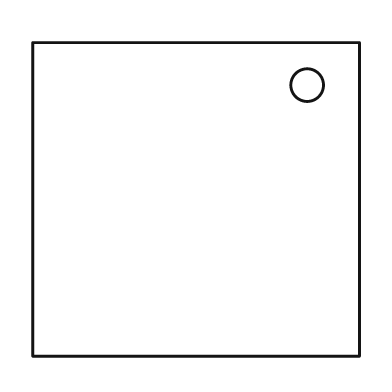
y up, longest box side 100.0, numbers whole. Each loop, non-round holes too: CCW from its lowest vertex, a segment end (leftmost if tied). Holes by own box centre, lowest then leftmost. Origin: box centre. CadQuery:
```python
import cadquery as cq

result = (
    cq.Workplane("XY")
    .moveTo(-50.0, -48.0)
    .lineTo(50.0, -48.0)
    .lineTo(50.0, 48.0)
    .lineTo(-50.0, 48.0)
    .close()
    .moveTo(34.0, 35.0)
    .circle(5.0)
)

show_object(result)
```